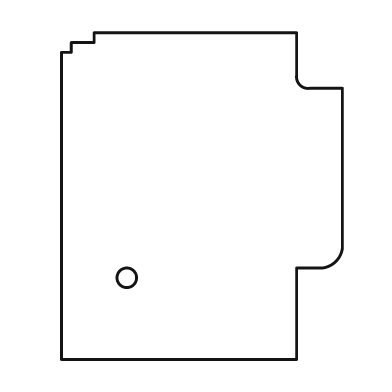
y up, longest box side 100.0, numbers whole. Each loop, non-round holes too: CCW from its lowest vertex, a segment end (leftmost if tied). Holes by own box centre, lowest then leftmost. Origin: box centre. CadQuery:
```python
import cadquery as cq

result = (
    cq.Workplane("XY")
    .moveTo(-43.0, -50.0)
    .lineTo(29.0, -50.0)
    .lineTo(29.0, -22.0)
    .lineTo(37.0, -22.0)
    .threePointArc((41.0, -20.0), (43.0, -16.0))
    .lineTo(43.0, 33.0)
    .lineTo(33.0, 33.0)
    .threePointArc((30.0, 34.0), (29.0, 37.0))
    .lineTo(29.0, 50.0)
    .lineTo(-33.0, 50.0)
    .lineTo(-33.0, 47.0)
    .lineTo(-40.0, 47.0)
    .lineTo(-40.0, 44.0)
    .lineTo(-43.0, 44.0)
    .close()
    .moveTo(-23.0, -25.0)
    .circle(3.0)
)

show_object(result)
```